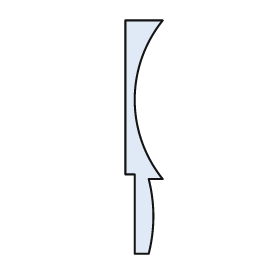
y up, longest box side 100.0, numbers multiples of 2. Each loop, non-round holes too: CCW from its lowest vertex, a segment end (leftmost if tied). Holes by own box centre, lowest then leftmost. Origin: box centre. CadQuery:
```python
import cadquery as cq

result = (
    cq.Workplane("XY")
    .moveTo(-4.0, -50.0)
    .lineTo(2.0, -50.0)
    .threePointArc((4.0, -34.0), (2.0, -18.0))
    .lineTo(8.0, -18.0)
    .threePointArc((-4.0, 16.0), (8.0, 50.0))
    .lineTo(-8.0, 50.0)
    .lineTo(-8.0, -16.0)
    .lineTo(-4.0, -16.0)
    .close()
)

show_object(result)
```